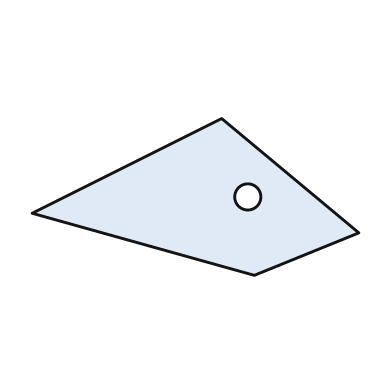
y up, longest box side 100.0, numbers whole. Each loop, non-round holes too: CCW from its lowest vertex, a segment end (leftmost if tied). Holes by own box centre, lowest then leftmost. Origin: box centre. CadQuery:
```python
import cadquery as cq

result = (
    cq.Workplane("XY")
    .moveTo(18.0, -24.0)
    .lineTo(50.0, -11.0)
    .lineTo(8.0, 24.0)
    .lineTo(-50.0, -5.0)
    .close()
    .moveTo(16.0, 0.0)
    .circle(4.0)
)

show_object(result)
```